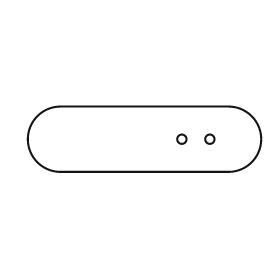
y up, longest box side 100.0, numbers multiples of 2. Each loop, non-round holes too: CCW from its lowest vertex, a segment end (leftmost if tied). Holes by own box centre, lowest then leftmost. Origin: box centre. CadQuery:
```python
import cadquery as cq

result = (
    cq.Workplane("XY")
    .moveTo(-36.0, -14.0)
    .lineTo(36.0, -14.0)
    .threePointArc((50.0, 0.0), (36.0, 14.0))
    .lineTo(-36.0, 14.0)
    .threePointArc((-50.0, 0.0), (-36.0, -14.0))
    .close()
    .moveTo(16.0, 0.0)
    .circle(2.0)
    .moveTo(28.0, 0.0)
    .circle(2.0)
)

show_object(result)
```